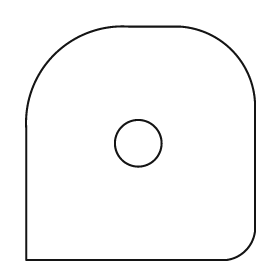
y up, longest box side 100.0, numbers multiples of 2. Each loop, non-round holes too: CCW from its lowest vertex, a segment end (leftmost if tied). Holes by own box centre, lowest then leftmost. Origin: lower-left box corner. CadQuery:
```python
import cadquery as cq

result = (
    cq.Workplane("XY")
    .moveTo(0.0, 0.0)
    .lineTo(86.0, 0.0)
    .threePointArc((94.0, 4.0), (98.0, 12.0))
    .lineTo(98.0, 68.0)
    .threePointArc((88.0, 90.0), (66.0, 100.0))
    .lineTo(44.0, 100.0)
    .threePointArc((12.0, 88.0), (0.0, 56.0))
    .close()
    .moveTo(48.0, 50.0)
    .circle(10.0)
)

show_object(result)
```